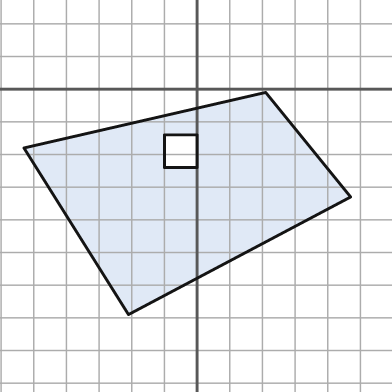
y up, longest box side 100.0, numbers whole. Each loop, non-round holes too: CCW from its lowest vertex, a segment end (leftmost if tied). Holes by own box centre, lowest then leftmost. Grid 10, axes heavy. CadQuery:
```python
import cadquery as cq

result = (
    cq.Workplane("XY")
    .moveTo(-21.0, -69.0)
    .lineTo(47.0, -33.0)
    .lineTo(21.0, -1.0)
    .lineTo(-53.0, -18.0)
    .close()
    .moveTo(-10.0, -24.0)
    .lineTo(0.0, -24.0)
    .lineTo(0.0, -14.0)
    .lineTo(-10.0, -14.0)
    .close()
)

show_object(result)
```